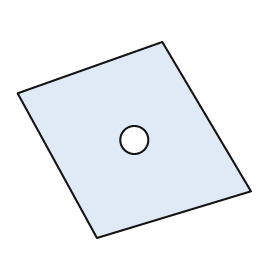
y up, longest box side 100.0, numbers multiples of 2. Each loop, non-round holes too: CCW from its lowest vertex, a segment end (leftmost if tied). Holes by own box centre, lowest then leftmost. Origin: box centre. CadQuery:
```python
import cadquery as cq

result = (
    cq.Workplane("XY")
    .moveTo(-16.0, -42.0)
    .lineTo(50.0, -22.0)
    .lineTo(12.0, 42.0)
    .lineTo(-50.0, 20.0)
    .close()
    .moveTo(0.0, 0.0)
    .circle(6.0)
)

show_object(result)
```